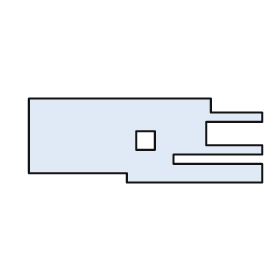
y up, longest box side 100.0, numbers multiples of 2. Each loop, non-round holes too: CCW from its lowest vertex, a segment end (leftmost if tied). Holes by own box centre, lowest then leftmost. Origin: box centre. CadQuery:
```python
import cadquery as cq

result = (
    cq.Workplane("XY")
    .moveTo(-8.0, -18.0)
    .lineTo(50.0, -18.0)
    .lineTo(50.0, -10.0)
    .lineTo(12.0, -10.0)
    .lineTo(12.0, -6.0)
    .lineTo(50.0, -6.0)
    .lineTo(50.0, -2.0)
    .lineTo(26.0, -2.0)
    .lineTo(26.0, 8.0)
    .lineTo(50.0, 8.0)
    .lineTo(50.0, 12.0)
    .lineTo(28.0, 12.0)
    .lineTo(28.0, 18.0)
    .lineTo(-50.0, 18.0)
    .lineTo(-50.0, -14.0)
    .lineTo(-8.0, -14.0)
    .close()
    .moveTo(-4.0, -4.0)
    .lineTo(4.0, -4.0)
    .lineTo(4.0, 4.0)
    .lineTo(-4.0, 4.0)
    .close()
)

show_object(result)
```